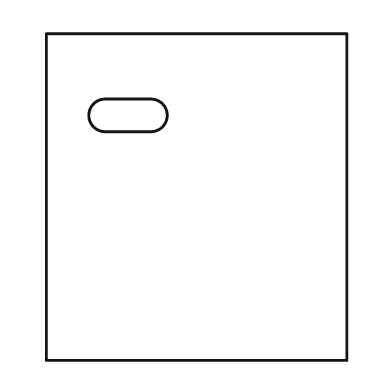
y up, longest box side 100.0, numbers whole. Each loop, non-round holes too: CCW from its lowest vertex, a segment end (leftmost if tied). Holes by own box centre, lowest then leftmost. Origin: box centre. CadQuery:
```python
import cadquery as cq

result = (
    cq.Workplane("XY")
    .moveTo(-46.0, -50.0)
    .lineTo(46.0, -50.0)
    .lineTo(46.0, 50.0)
    .lineTo(-46.0, 50.0)
    .close()
    .moveTo(-28.0, 20.0)
    .lineTo(-14.0, 20.0)
    .threePointArc((-9.0, 25.0), (-14.0, 30.0))
    .lineTo(-28.0, 30.0)
    .threePointArc((-33.0, 25.0), (-28.0, 20.0))
    .close()
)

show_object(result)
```